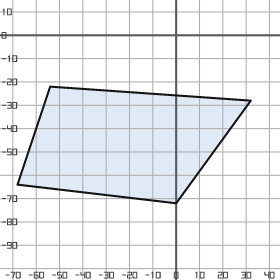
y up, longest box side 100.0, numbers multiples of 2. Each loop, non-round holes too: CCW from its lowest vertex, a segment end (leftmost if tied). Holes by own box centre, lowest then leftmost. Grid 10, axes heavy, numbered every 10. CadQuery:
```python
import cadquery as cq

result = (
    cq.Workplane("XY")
    .moveTo(0.0, -72.0)
    .lineTo(32.0, -28.0)
    .lineTo(-54.0, -22.0)
    .lineTo(-68.0, -64.0)
    .close()
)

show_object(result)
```